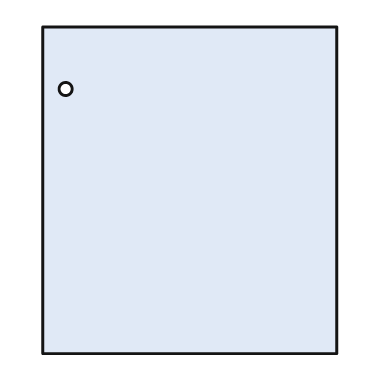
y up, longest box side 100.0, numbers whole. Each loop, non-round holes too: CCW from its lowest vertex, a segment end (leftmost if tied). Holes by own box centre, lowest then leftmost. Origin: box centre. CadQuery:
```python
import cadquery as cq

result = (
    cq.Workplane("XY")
    .moveTo(-45.0, -50.0)
    .lineTo(45.0, -50.0)
    .lineTo(45.0, 50.0)
    .lineTo(-45.0, 50.0)
    .close()
    .moveTo(-38.0, 31.0)
    .circle(2.0)
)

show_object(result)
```